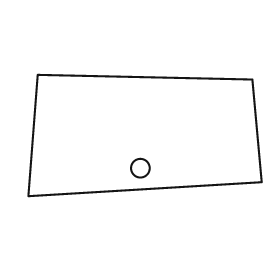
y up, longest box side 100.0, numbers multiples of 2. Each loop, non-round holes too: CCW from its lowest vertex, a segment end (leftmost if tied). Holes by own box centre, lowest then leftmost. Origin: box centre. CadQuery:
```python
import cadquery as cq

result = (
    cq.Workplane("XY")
    .moveTo(-50.0, -26.0)
    .lineTo(50.0, -20.0)
    .lineTo(46.0, 24.0)
    .lineTo(-46.0, 26.0)
    .close()
    .moveTo(-2.0, -14.0)
    .circle(4.0)
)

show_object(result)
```